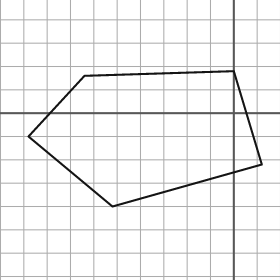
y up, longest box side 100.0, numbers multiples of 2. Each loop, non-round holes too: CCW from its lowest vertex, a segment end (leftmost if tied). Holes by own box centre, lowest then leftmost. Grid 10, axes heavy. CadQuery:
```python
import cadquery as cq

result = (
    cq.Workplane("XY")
    .moveTo(-52.0, -40.0)
    .lineTo(12.0, -22.0)
    .lineTo(0.0, 18.0)
    .lineTo(-64.0, 16.0)
    .lineTo(-88.0, -10.0)
    .close()
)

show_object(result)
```